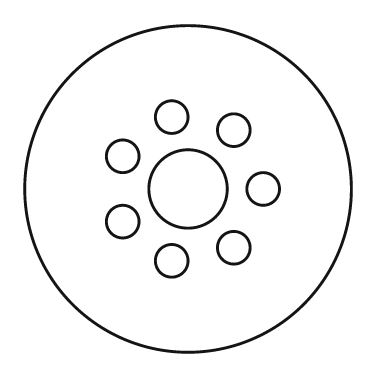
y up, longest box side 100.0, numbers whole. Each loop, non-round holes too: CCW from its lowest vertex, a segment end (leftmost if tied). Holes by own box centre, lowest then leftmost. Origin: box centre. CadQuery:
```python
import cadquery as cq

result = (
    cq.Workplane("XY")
    .moveTo(0.0, 0.0)
    .circle(50.0)
    .moveTo(-5.0, -22.0)
    .circle(5.0)
    .moveTo(14.0, -18.0)
    .circle(5.0)
    .moveTo(-20.0, -10.0)
    .circle(5.0)
    .moveTo(0.0, 0.0)
    .circle(12.0)
    .moveTo(23.0, 0.0)
    .circle(5.0)
    .moveTo(-20.0, 10.0)
    .circle(5.0)
    .moveTo(14.0, 18.0)
    .circle(5.0)
    .moveTo(-5.0, 22.0)
    .circle(5.0)
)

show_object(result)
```